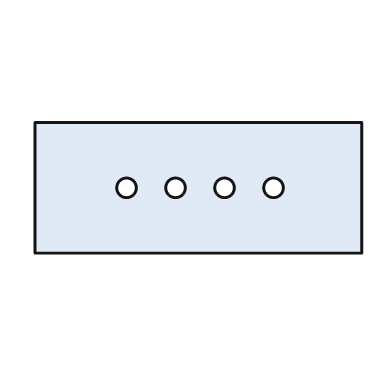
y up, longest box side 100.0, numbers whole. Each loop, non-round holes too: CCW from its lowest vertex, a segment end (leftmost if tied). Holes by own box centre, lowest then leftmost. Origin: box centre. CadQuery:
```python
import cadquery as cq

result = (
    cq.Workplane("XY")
    .moveTo(-50.0, -20.0)
    .lineTo(50.0, -20.0)
    .lineTo(50.0, 20.0)
    .lineTo(-50.0, 20.0)
    .close()
    .moveTo(-22.0, 0.0)
    .circle(3.0)
    .moveTo(-7.0, 0.0)
    .circle(3.0)
    .moveTo(8.0, 0.0)
    .circle(3.0)
    .moveTo(23.0, 0.0)
    .circle(3.0)
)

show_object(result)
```